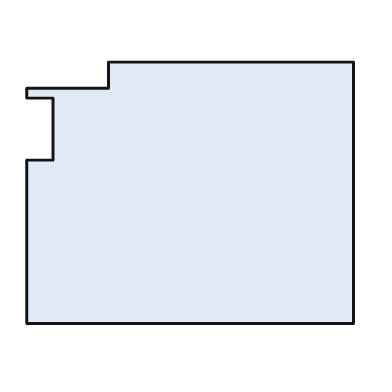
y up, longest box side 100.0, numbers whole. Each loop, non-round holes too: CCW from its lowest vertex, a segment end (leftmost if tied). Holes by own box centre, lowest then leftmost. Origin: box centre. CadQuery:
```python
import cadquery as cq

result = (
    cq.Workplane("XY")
    .moveTo(-50.0, -40.0)
    .lineTo(50.0, -40.0)
    .lineTo(50.0, 40.0)
    .lineTo(-25.0, 40.0)
    .lineTo(-25.0, 32.0)
    .lineTo(-50.0, 32.0)
    .lineTo(-50.0, 29.0)
    .lineTo(-42.0, 29.0)
    .lineTo(-42.0, 10.0)
    .lineTo(-50.0, 10.0)
    .close()
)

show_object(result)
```